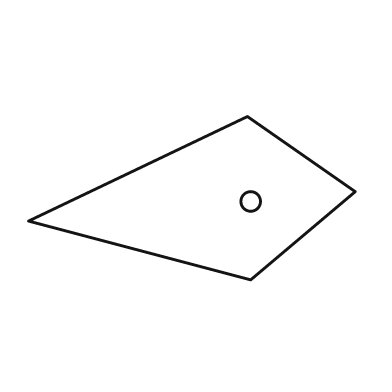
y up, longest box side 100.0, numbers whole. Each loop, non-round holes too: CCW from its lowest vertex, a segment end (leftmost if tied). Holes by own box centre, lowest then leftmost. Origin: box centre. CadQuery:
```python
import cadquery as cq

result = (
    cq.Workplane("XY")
    .moveTo(18.0, -25.0)
    .lineTo(50.0, 2.0)
    .lineTo(17.0, 25.0)
    .lineTo(-50.0, -7.0)
    .close()
    .moveTo(18.0, -1.0)
    .circle(3.0)
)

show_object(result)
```